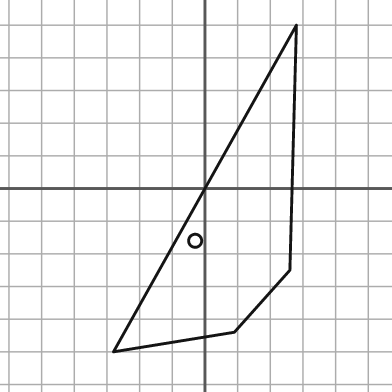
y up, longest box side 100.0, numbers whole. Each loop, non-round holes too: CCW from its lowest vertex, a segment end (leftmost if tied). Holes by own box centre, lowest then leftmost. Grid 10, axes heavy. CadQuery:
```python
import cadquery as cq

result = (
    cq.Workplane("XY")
    .moveTo(-28.0, -50.0)
    .lineTo(9.0, -44.0)
    .lineTo(26.0, -25.0)
    .lineTo(28.0, 50.0)
    .close()
    .moveTo(-3.0, -16.0)
    .circle(2.0)
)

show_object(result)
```